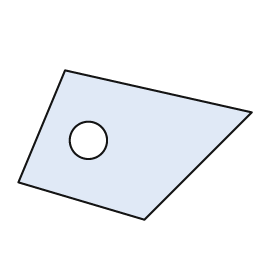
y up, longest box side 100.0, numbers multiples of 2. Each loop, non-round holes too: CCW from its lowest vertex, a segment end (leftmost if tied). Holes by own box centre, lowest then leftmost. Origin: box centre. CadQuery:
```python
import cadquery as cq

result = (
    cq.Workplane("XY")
    .moveTo(4.0, -32.0)
    .lineTo(50.0, 14.0)
    .lineTo(-30.0, 32.0)
    .lineTo(-50.0, -16.0)
    .close()
    .moveTo(-20.0, 2.0)
    .circle(8.0)
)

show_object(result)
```